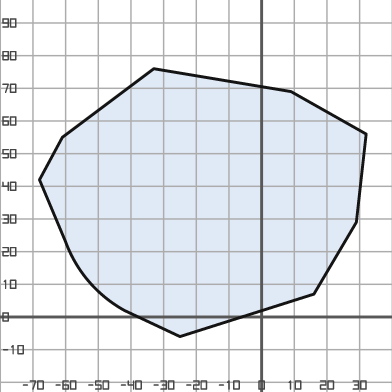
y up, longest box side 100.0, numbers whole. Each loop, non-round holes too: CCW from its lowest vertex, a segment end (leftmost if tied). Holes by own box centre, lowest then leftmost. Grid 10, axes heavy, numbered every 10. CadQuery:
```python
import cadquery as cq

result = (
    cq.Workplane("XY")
    .moveTo(-25.0, -6.0)
    .lineTo(16.0, 7.0)
    .lineTo(29.0, 29.0)
    .lineTo(32.0, 56.0)
    .lineTo(9.0, 69.0)
    .lineTo(-33.0, 76.0)
    .lineTo(-61.0, 55.0)
    .lineTo(-68.0, 42.0)
    .lineTo(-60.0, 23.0)
    .threePointArc((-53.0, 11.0), (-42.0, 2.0))
    .close()
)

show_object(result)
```